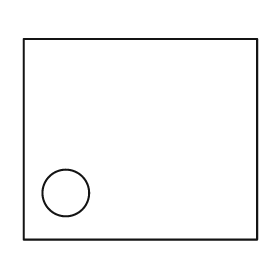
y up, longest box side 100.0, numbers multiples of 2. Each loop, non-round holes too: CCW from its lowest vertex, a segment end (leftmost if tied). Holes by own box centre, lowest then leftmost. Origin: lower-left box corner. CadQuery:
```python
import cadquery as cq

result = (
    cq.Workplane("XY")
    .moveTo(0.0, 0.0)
    .lineTo(100.0, 0.0)
    .lineTo(100.0, 86.0)
    .lineTo(0.0, 86.0)
    .close()
    .moveTo(18.0, 20.0)
    .circle(10.0)
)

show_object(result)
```